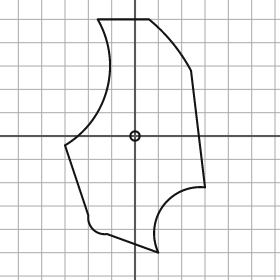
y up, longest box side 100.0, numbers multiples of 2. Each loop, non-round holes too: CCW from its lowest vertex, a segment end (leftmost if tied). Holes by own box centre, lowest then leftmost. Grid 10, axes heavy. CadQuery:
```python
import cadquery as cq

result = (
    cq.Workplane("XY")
    .moveTo(10.0, -50.0)
    .threePointArc((12.0, -30.0), (30.0, -22.0))
    .lineTo(24.0, 28.0)
    .threePointArc((16.0, 40.0), (6.0, 50.0))
    .lineTo(-16.0, 50.0)
    .threePointArc((-12.0, 20.0), (-30.0, -4.0))
    .lineTo(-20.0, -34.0)
    .threePointArc((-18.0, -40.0), (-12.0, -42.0))
    .close()
    .moveTo(0.0, 0.0)
    .circle(2.0)
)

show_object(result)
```